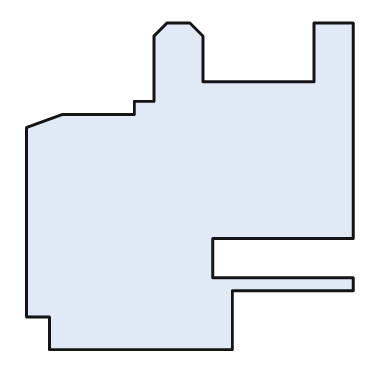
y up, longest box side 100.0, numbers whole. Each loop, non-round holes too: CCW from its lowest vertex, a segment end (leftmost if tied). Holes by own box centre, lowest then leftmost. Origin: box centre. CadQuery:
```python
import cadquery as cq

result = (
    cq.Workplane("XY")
    .moveTo(-43.0, -50.0)
    .lineTo(13.0, -50.0)
    .lineTo(13.0, -32.0)
    .lineTo(50.0, -32.0)
    .lineTo(50.0, -28.0)
    .lineTo(7.0, -28.0)
    .lineTo(7.0, -16.0)
    .lineTo(50.0, -16.0)
    .lineTo(50.0, 50.0)
    .lineTo(38.0, 50.0)
    .lineTo(38.0, 32.0)
    .lineTo(4.0, 32.0)
    .lineTo(4.0, 46.0)
    .lineTo(0.0, 50.0)
    .lineTo(-7.0, 50.0)
    .lineTo(-11.0, 46.0)
    .lineTo(-11.0, 26.0)
    .lineTo(-17.0, 26.0)
    .lineTo(-17.0, 22.0)
    .lineTo(-39.0, 22.0)
    .lineTo(-50.0, 18.0)
    .lineTo(-50.0, -40.0)
    .lineTo(-43.0, -40.0)
    .close()
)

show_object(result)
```